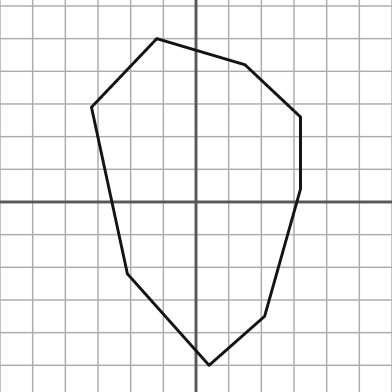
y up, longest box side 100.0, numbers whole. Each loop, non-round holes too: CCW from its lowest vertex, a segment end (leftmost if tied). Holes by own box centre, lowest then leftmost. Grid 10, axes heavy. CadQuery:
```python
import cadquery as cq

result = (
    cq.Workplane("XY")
    .moveTo(4.0, -50.0)
    .lineTo(21.0, -35.0)
    .lineTo(32.0, 4.0)
    .lineTo(32.0, 26.0)
    .lineTo(15.0, 42.0)
    .lineTo(-12.0, 50.0)
    .lineTo(-32.0, 29.0)
    .lineTo(-21.0, -22.0)
    .close()
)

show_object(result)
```